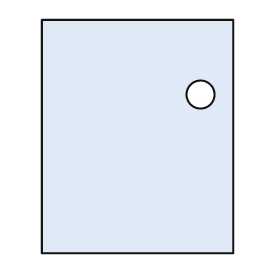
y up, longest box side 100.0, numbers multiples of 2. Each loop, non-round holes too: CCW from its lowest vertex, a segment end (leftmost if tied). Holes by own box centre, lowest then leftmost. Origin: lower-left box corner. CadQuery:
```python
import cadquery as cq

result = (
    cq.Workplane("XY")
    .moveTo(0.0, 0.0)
    .lineTo(82.0, 0.0)
    .lineTo(82.0, 100.0)
    .lineTo(0.0, 100.0)
    .close()
    .moveTo(68.0, 68.0)
    .circle(6.0)
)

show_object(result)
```